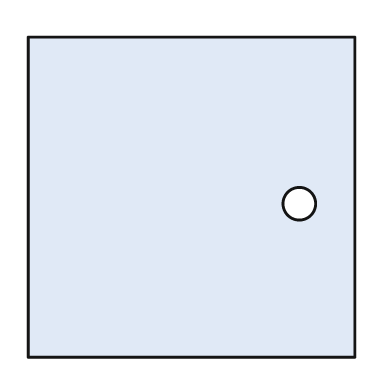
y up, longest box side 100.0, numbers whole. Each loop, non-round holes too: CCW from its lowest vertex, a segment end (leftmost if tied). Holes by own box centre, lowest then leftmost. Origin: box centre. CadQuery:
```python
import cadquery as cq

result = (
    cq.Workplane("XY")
    .moveTo(-50.0, -49.0)
    .lineTo(50.0, -49.0)
    .lineTo(50.0, 49.0)
    .lineTo(-50.0, 49.0)
    .close()
    .moveTo(33.0, -2.0)
    .circle(5.0)
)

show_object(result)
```